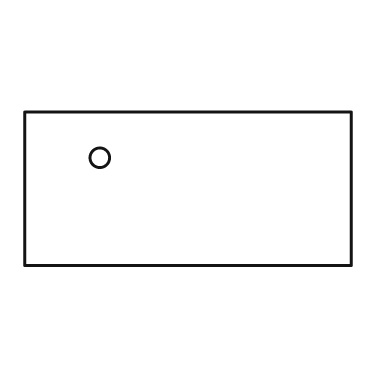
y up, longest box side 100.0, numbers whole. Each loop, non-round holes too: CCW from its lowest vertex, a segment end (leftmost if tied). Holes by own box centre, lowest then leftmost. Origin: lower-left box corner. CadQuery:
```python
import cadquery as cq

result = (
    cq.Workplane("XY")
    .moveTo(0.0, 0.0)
    .lineTo(100.0, 0.0)
    .lineTo(100.0, 47.0)
    .lineTo(0.0, 47.0)
    .close()
    .moveTo(23.0, 33.0)
    .circle(3.0)
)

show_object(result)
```